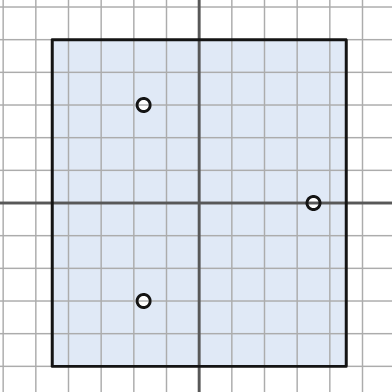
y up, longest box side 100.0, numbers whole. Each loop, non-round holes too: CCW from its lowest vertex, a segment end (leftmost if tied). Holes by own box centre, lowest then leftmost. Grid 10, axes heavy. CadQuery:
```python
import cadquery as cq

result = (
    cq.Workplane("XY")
    .moveTo(-45.0, -50.0)
    .lineTo(45.0, -50.0)
    .lineTo(45.0, 50.0)
    .lineTo(-45.0, 50.0)
    .close()
    .moveTo(-17.0, -30.0)
    .circle(2.0)
    .moveTo(35.0, 0.0)
    .circle(2.0)
    .moveTo(-17.0, 30.0)
    .circle(2.0)
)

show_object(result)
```